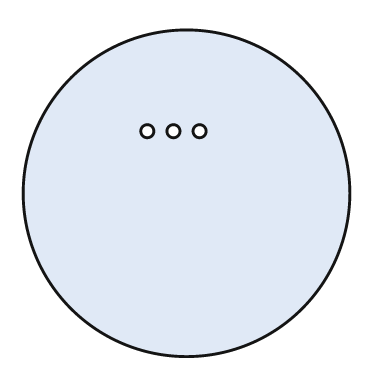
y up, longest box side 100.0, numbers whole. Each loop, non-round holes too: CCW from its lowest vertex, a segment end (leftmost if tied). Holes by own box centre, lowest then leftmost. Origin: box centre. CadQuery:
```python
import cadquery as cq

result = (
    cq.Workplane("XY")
    .moveTo(0.0, 0.0)
    .circle(50.0)
    .moveTo(-12.0, 19.0)
    .circle(2.0)
    .moveTo(-4.0, 19.0)
    .circle(2.0)
    .moveTo(4.0, 19.0)
    .circle(2.0)
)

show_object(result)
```